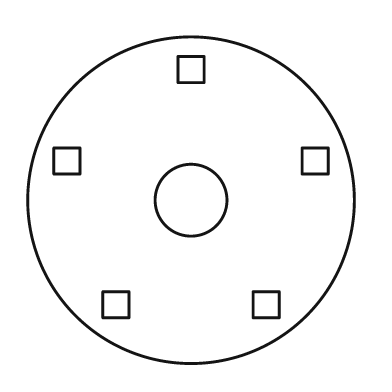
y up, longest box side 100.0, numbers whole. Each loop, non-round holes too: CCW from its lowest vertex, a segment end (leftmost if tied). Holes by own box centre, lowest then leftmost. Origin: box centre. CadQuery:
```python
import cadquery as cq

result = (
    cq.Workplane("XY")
    .moveTo(0.0, 0.0)
    .circle(50.0)
    .moveTo(-27.0, -36.0)
    .lineTo(-19.0, -36.0)
    .lineTo(-19.0, -28.0)
    .lineTo(-27.0, -28.0)
    .close()
    .moveTo(19.0, -36.0)
    .lineTo(27.0, -36.0)
    .lineTo(27.0, -28.0)
    .lineTo(19.0, -28.0)
    .close()
    .moveTo(0.0, 0.0)
    .circle(11.0)
    .moveTo(-42.0, 8.0)
    .lineTo(-34.0, 8.0)
    .lineTo(-34.0, 16.0)
    .lineTo(-42.0, 16.0)
    .close()
    .moveTo(34.0, 8.0)
    .lineTo(42.0, 8.0)
    .lineTo(42.0, 16.0)
    .lineTo(34.0, 16.0)
    .close()
    .moveTo(-4.0, 36.0)
    .lineTo(4.0, 36.0)
    .lineTo(4.0, 44.0)
    .lineTo(-4.0, 44.0)
    .close()
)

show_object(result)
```